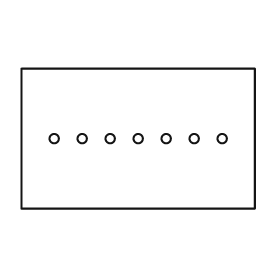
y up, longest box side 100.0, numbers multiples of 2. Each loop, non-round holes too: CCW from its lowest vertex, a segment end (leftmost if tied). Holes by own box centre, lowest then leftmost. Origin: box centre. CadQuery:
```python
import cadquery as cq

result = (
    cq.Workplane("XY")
    .moveTo(-50.0, -30.0)
    .lineTo(50.0, -30.0)
    .lineTo(50.0, 30.0)
    .lineTo(-50.0, 30.0)
    .close()
    .moveTo(-36.0, 0.0)
    .circle(2.0)
    .moveTo(-24.0, 0.0)
    .circle(2.0)
    .moveTo(-12.0, 0.0)
    .circle(2.0)
    .moveTo(0.0, 0.0)
    .circle(2.0)
    .moveTo(12.0, 0.0)
    .circle(2.0)
    .moveTo(24.0, 0.0)
    .circle(2.0)
    .moveTo(36.0, 0.0)
    .circle(2.0)
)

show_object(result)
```